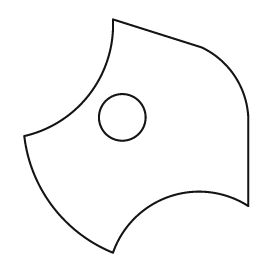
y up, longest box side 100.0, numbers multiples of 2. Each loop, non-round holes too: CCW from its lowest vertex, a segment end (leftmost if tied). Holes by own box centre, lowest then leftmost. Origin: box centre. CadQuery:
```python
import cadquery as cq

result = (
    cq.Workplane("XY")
    .moveTo(-10.0, -50.0)
    .threePointArc((14.0, -26.0), (48.0, -30.0))
    .lineTo(48.0, 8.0)
    .threePointArc((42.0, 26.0), (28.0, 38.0))
    .lineTo(-10.0, 50.0)
    .threePointArc((-20.0, 18.0), (-48.0, 0.0))
    .threePointArc((-36.0, -30.0), (-10.0, -50.0))
    .close()
    .moveTo(-6.0, 8.0)
    .circle(10.0)
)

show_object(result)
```